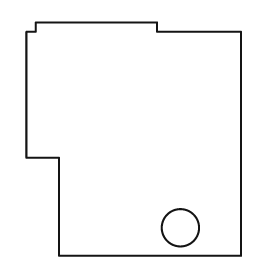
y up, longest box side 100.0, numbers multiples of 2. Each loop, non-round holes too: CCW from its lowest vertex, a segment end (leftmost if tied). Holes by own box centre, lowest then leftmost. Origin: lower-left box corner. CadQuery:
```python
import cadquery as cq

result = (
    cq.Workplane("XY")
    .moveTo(14.0, 0.0)
    .lineTo(92.0, 0.0)
    .lineTo(92.0, 96.0)
    .lineTo(56.0, 96.0)
    .lineTo(56.0, 100.0)
    .lineTo(4.0, 100.0)
    .lineTo(4.0, 96.0)
    .lineTo(0.0, 96.0)
    .lineTo(0.0, 42.0)
    .lineTo(14.0, 42.0)
    .close()
    .moveTo(66.0, 12.0)
    .circle(8.0)
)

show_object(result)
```